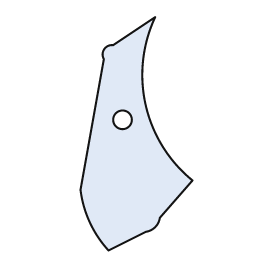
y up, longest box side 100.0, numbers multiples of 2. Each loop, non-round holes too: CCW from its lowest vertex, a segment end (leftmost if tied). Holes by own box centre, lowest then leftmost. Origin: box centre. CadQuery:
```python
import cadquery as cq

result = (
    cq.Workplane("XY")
    .moveTo(-12.0, -50.0)
    .lineTo(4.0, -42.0)
    .threePointArc((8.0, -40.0), (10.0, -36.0))
    .lineTo(24.0, -20.0)
    .threePointArc((4.0, 12.0), (8.0, 50.0))
    .lineTo(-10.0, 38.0)
    .threePointArc((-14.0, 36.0), (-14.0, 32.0))
    .lineTo(-24.0, -24.0)
    .threePointArc((-20.0, -38.0), (-12.0, -50.0))
    .close()
    .moveTo(-6.0, 6.0)
    .circle(4.0)
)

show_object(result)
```